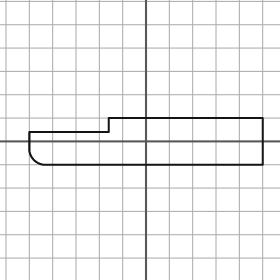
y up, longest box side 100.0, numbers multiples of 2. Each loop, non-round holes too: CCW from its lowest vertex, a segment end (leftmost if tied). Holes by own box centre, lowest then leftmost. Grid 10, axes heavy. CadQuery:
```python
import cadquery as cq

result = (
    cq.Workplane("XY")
    .moveTo(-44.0, -10.0)
    .lineTo(50.0, -10.0)
    .lineTo(50.0, 10.0)
    .lineTo(-16.0, 10.0)
    .lineTo(-16.0, 4.0)
    .lineTo(-50.0, 4.0)
    .lineTo(-50.0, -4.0)
    .threePointArc((-48.0, -8.0), (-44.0, -10.0))
    .close()
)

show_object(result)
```